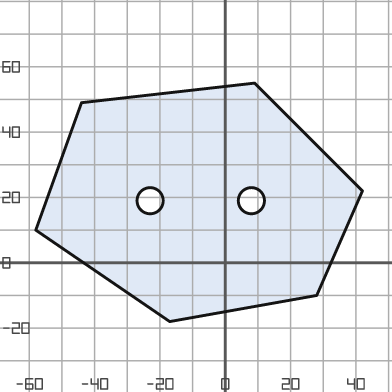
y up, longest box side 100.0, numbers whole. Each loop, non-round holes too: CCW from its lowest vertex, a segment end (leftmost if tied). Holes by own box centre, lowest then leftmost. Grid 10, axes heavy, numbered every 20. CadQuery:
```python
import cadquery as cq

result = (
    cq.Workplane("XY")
    .moveTo(-17.0, -18.0)
    .lineTo(28.0, -10.0)
    .lineTo(42.0, 22.0)
    .lineTo(9.0, 55.0)
    .lineTo(-44.0, 49.0)
    .lineTo(-58.0, 10.0)
    .close()
    .moveTo(-23.0, 19.0)
    .circle(4.0)
    .moveTo(8.0, 19.0)
    .circle(4.0)
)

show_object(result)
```